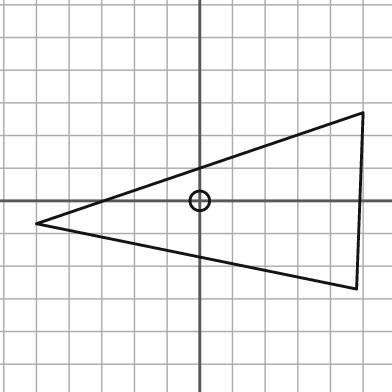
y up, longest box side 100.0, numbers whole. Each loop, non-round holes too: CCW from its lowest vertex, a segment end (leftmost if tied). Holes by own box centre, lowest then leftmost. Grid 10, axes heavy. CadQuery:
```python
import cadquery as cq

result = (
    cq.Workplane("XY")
    .moveTo(48.0, -27.0)
    .lineTo(50.0, 27.0)
    .lineTo(-50.0, -7.0)
    .close()
    .moveTo(0.0, 0.0)
    .circle(3.0)
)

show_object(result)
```